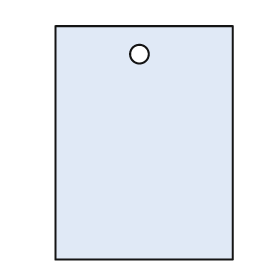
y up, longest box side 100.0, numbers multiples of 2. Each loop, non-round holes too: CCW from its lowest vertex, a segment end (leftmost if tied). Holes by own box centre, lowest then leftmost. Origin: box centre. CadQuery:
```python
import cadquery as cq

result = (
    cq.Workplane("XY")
    .moveTo(-38.0, -50.0)
    .lineTo(38.0, -50.0)
    .lineTo(38.0, 50.0)
    .lineTo(-38.0, 50.0)
    .close()
    .moveTo(-2.0, 38.0)
    .circle(4.0)
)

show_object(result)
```